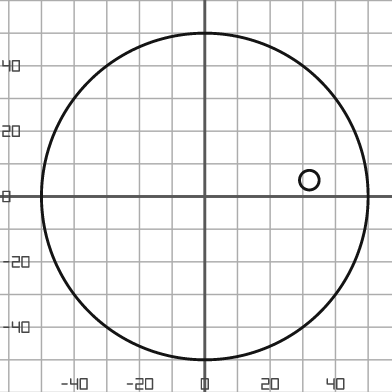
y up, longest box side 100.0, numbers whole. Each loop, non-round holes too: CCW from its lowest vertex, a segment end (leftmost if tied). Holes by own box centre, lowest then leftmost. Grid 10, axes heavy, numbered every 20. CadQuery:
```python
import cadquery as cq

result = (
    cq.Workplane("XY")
    .moveTo(0.0, 0.0)
    .circle(50.0)
    .moveTo(32.0, 5.0)
    .circle(3.0)
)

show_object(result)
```